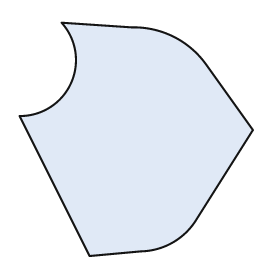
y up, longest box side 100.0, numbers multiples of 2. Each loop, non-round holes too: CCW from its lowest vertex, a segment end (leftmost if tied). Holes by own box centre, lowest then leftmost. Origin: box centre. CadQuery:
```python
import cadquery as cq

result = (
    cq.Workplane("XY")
    .moveTo(-20.0, -50.0)
    .lineTo(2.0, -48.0)
    .threePointArc((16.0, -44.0), (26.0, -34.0))
    .lineTo(50.0, 4.0)
    .lineTo(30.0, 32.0)
    .threePointArc((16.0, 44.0), (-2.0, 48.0))
    .lineTo(-32.0, 50.0)
    .threePointArc((-28.0, 24.0), (-50.0, 10.0))
    .close()
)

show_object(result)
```